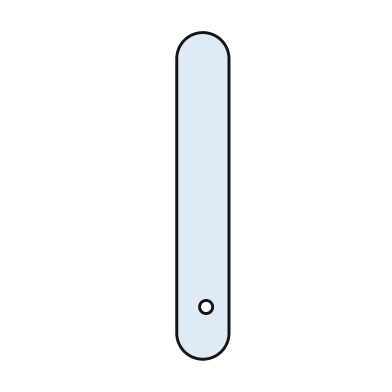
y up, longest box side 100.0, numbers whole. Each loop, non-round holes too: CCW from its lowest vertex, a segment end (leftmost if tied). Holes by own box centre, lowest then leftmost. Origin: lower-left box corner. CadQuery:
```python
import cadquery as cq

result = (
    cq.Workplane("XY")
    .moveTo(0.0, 8.0)
    .threePointArc((8.0, 0.0), (16.0, 8.0))
    .lineTo(16.0, 92.0)
    .threePointArc((8.0, 100.0), (0.0, 92.0))
    .close()
    .moveTo(9.0, 16.0)
    .circle(2.0)
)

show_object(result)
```